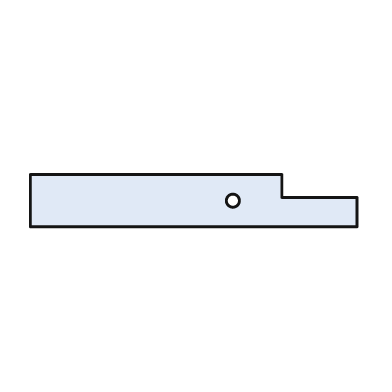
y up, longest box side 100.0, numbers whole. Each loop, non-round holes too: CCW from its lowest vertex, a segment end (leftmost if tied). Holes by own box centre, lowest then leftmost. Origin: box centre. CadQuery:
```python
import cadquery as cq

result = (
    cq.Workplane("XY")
    .moveTo(-50.0, -8.0)
    .lineTo(50.0, -8.0)
    .lineTo(50.0, 1.0)
    .lineTo(27.0, 1.0)
    .lineTo(27.0, 8.0)
    .lineTo(-50.0, 8.0)
    .close()
    .moveTo(12.0, 0.0)
    .circle(2.0)
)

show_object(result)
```